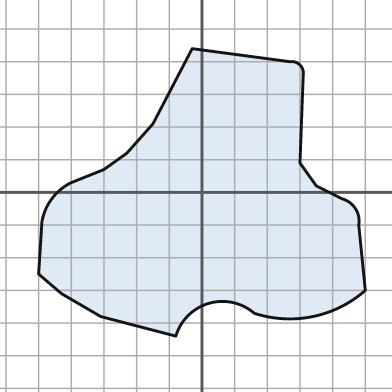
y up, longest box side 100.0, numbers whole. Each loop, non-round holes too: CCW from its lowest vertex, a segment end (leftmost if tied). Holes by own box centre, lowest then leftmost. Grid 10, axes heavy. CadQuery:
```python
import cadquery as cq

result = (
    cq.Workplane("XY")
    .moveTo(-8.0, -44.0)
    .threePointArc((2.0, -34.0), (16.0, -37.0))
    .threePointArc((34.0, -38.0), (50.0, -30.0))
    .lineTo(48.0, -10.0)
    .threePointArc((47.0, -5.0), (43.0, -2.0))
    .lineTo(35.0, 2.0)
    .lineTo(30.0, 9.0)
    .lineTo(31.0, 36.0)
    .threePointArc((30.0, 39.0), (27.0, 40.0))
    .lineTo(-3.0, 44.0)
    .lineTo(-15.0, 21.0)
    .lineTo(-23.0, 12.0)
    .lineTo(-30.0, 7.0)
    .lineTo(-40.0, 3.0)
    .threePointArc((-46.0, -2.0), (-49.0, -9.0))
    .lineTo(-50.0, -25.0)
    .lineTo(-43.0, -31.0)
    .lineTo(-31.0, -38.0)
    .close()
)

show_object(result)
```